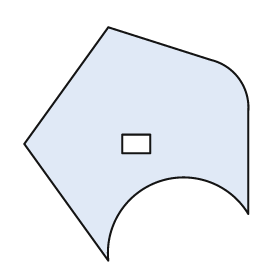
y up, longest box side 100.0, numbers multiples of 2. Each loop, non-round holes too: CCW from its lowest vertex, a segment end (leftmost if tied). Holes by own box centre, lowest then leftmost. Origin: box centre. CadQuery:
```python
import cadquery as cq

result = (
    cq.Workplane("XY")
    .moveTo(-12.0, -50.0)
    .threePointArc((10.0, -16.0), (48.0, -30.0))
    .lineTo(48.0, 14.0)
    .threePointArc((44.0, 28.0), (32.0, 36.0))
    .lineTo(-12.0, 50.0)
    .lineTo(-48.0, 0.0)
    .close()
    .moveTo(-6.0, -4.0)
    .lineTo(6.0, -4.0)
    .lineTo(6.0, 4.0)
    .lineTo(-6.0, 4.0)
    .close()
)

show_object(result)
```